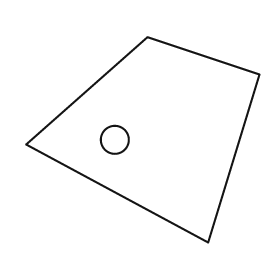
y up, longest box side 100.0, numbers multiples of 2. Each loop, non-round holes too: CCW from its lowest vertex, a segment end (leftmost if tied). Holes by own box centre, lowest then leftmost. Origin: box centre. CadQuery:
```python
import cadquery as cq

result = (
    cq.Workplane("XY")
    .moveTo(28.0, -44.0)
    .lineTo(50.0, 28.0)
    .lineTo(2.0, 44.0)
    .lineTo(-50.0, -2.0)
    .close()
    .moveTo(-12.0, 0.0)
    .circle(6.0)
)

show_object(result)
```